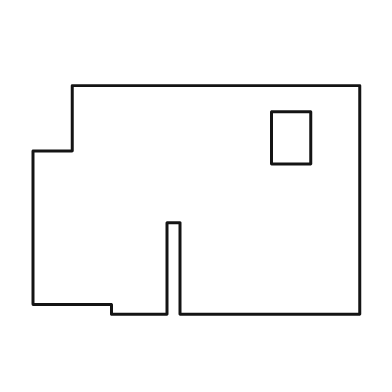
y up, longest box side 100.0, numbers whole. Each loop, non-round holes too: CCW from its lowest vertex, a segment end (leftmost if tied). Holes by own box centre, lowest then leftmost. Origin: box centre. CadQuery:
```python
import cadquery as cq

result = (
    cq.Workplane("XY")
    .moveTo(-26.0, -35.0)
    .lineTo(-9.0, -35.0)
    .lineTo(-9.0, -7.0)
    .lineTo(-5.0, -7.0)
    .lineTo(-5.0, -35.0)
    .lineTo(50.0, -35.0)
    .lineTo(50.0, 35.0)
    .lineTo(-38.0, 35.0)
    .lineTo(-38.0, 15.0)
    .lineTo(-50.0, 15.0)
    .lineTo(-50.0, -32.0)
    .lineTo(-26.0, -32.0)
    .close()
    .moveTo(23.0, 11.0)
    .lineTo(35.0, 11.0)
    .lineTo(35.0, 27.0)
    .lineTo(23.0, 27.0)
    .close()
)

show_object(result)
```